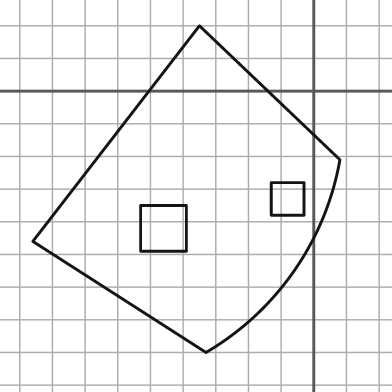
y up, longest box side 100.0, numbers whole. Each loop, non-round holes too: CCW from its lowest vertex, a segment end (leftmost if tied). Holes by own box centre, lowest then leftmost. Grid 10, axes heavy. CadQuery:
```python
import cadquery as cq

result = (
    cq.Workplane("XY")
    .moveTo(-33.0, -80.0)
    .threePointArc((-6.0, -55.0), (8.0, -21.0))
    .lineTo(-35.0, 20.0)
    .lineTo(-86.0, -46.0)
    .close()
    .moveTo(-53.0, -49.0)
    .lineTo(-39.0, -49.0)
    .lineTo(-39.0, -35.0)
    .lineTo(-53.0, -35.0)
    .close()
    .moveTo(-13.0, -38.0)
    .lineTo(-3.0, -38.0)
    .lineTo(-3.0, -28.0)
    .lineTo(-13.0, -28.0)
    .close()
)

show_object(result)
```